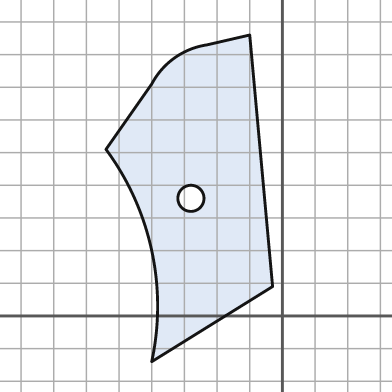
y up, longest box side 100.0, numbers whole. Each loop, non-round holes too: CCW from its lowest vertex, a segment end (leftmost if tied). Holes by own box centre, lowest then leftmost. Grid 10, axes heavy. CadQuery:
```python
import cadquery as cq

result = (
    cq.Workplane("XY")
    .moveTo(-40.0, -14.0)
    .lineTo(-3.0, 9.0)
    .lineTo(-10.0, 86.0)
    .lineTo(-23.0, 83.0)
    .threePointArc((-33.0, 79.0), (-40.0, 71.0))
    .lineTo(-54.0, 51.0)
    .threePointArc((-40.0, 20.0), (-40.0, -14.0))
    .close()
    .moveTo(-28.0, 36.0)
    .circle(4.0)
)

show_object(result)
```